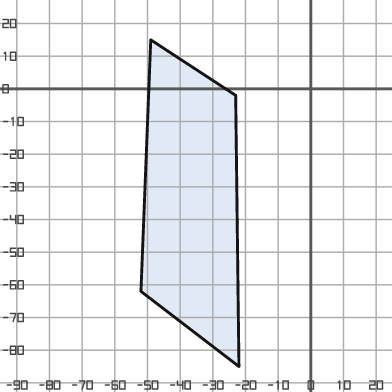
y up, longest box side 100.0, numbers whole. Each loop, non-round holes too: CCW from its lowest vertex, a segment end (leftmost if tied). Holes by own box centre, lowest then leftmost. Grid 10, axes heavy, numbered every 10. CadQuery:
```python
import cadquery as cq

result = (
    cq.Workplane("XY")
    .moveTo(-22.0, -85.0)
    .lineTo(-23.0, -2.0)
    .lineTo(-49.0, 15.0)
    .lineTo(-52.0, -62.0)
    .close()
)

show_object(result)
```